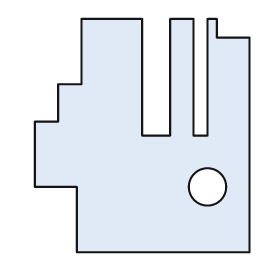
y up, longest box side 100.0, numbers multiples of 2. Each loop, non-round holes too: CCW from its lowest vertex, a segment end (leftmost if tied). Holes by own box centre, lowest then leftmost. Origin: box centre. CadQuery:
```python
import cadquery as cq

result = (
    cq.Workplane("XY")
    .moveTo(-28.0, -50.0)
    .lineTo(46.0, -50.0)
    .lineTo(46.0, 42.0)
    .lineTo(32.0, 42.0)
    .lineTo(32.0, 50.0)
    .lineTo(28.0, 50.0)
    .lineTo(28.0, 0.0)
    .lineTo(22.0, 0.0)
    .lineTo(22.0, 50.0)
    .lineTo(12.0, 50.0)
    .lineTo(12.0, 0.0)
    .lineTo(0.0, 0.0)
    .lineTo(0.0, 50.0)
    .lineTo(-26.0, 50.0)
    .lineTo(-26.0, 22.0)
    .lineTo(-36.0, 22.0)
    .lineTo(-36.0, 6.0)
    .lineTo(-46.0, 6.0)
    .lineTo(-46.0, -22.0)
    .lineTo(-28.0, -22.0)
    .close()
    .moveTo(28.0, -22.0)
    .circle(8.0)
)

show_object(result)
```